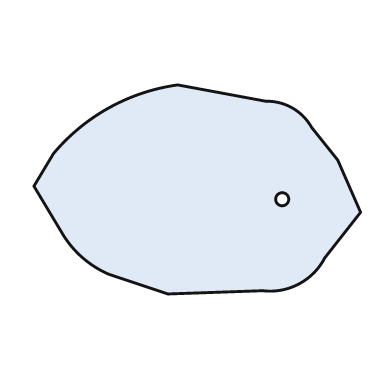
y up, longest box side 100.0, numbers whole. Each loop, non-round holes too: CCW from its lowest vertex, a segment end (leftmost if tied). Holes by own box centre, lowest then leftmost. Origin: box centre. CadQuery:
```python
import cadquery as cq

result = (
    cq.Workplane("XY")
    .moveTo(-9.0, -32.0)
    .lineTo(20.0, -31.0)
    .threePointArc((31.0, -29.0), (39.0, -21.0))
    .lineTo(50.0, -7.0)
    .lineTo(43.0, 9.0)
    .lineTo(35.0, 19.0)
    .threePointArc((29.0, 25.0), (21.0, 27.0))
    .lineTo(-6.0, 32.0)
    .threePointArc((-27.0, 25.0), (-44.0, 11.0))
    .lineTo(-50.0, 1.0)
    .lineTo(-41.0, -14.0)
    .threePointArc((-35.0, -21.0), (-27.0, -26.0))
    .close()
    .moveTo(26.0, -3.0)
    .circle(2.0)
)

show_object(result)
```